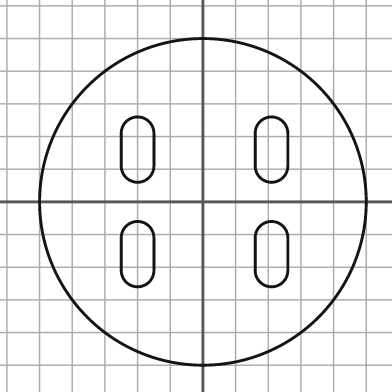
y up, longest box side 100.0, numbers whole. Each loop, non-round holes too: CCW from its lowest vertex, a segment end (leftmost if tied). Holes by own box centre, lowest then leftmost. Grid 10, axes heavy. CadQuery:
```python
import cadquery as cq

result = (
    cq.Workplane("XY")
    .moveTo(0.0, 0.0)
    .circle(50.0)
    .moveTo(-25.0, -21.0)
    .threePointArc((-20.0, -26.0), (-15.0, -21.0))
    .lineTo(-15.0, -11.0)
    .threePointArc((-20.0, -6.0), (-25.0, -11.0))
    .close()
    .moveTo(16.0, -21.0)
    .threePointArc((21.0, -26.0), (26.0, -21.0))
    .lineTo(26.0, -11.0)
    .threePointArc((21.0, -6.0), (16.0, -11.0))
    .close()
    .moveTo(-25.0, 11.0)
    .threePointArc((-20.0, 6.0), (-15.0, 11.0))
    .lineTo(-15.0, 21.0)
    .threePointArc((-20.0, 26.0), (-25.0, 21.0))
    .close()
    .moveTo(16.0, 11.0)
    .threePointArc((21.0, 6.0), (26.0, 11.0))
    .lineTo(26.0, 21.0)
    .threePointArc((21.0, 26.0), (16.0, 21.0))
    .close()
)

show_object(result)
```